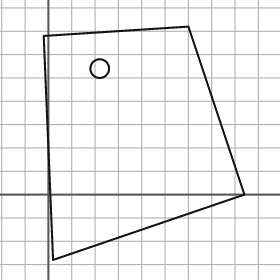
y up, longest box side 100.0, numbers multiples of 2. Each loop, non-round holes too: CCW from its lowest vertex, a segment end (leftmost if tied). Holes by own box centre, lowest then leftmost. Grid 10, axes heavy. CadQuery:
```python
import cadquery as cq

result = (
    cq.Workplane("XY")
    .moveTo(2.0, -28.0)
    .lineTo(84.0, 0.0)
    .lineTo(60.0, 72.0)
    .lineTo(-2.0, 68.0)
    .close()
    .moveTo(22.0, 54.0)
    .circle(4.0)
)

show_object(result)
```